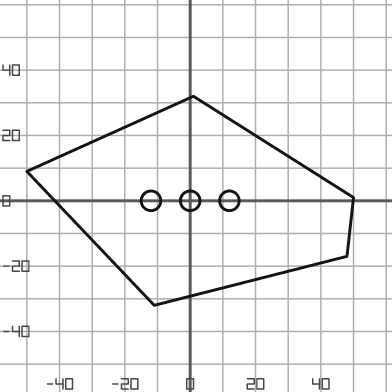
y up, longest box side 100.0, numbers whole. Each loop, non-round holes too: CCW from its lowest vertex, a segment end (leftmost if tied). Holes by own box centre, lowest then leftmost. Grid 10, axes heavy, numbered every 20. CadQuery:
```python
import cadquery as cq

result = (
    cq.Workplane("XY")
    .moveTo(-11.0, -32.0)
    .lineTo(48.0, -17.0)
    .lineTo(50.0, 1.0)
    .lineTo(1.0, 32.0)
    .lineTo(-50.0, 9.0)
    .close()
    .moveTo(-12.0, 0.0)
    .circle(3.0)
    .moveTo(0.0, 0.0)
    .circle(3.0)
    .moveTo(12.0, 0.0)
    .circle(3.0)
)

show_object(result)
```